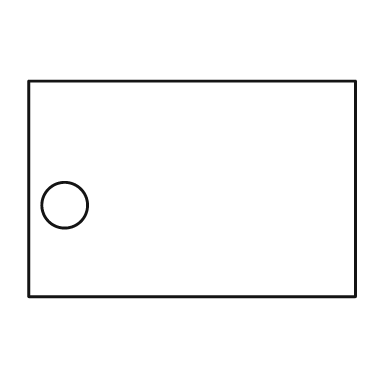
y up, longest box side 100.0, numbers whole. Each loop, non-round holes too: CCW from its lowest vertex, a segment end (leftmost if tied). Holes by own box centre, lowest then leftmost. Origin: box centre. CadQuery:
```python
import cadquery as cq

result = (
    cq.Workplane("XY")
    .moveTo(-50.0, -33.0)
    .lineTo(50.0, -33.0)
    .lineTo(50.0, 33.0)
    .lineTo(-50.0, 33.0)
    .close()
    .moveTo(-39.0, -5.0)
    .circle(7.0)
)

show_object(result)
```